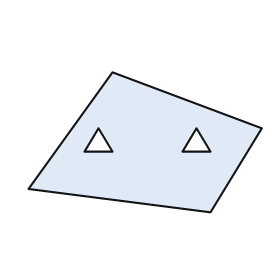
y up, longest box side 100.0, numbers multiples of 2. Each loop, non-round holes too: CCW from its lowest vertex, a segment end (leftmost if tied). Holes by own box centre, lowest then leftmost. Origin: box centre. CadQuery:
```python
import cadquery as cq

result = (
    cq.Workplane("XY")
    .moveTo(28.0, -30.0)
    .lineTo(50.0, 6.0)
    .lineTo(-14.0, 30.0)
    .lineTo(-50.0, -20.0)
    .close()
    .moveTo(-26.0, -4.0)
    .lineTo(-14.0, -4.0)
    .lineTo(-20.0, 6.0)
    .close()
    .moveTo(16.0, -4.0)
    .lineTo(28.0, -4.0)
    .lineTo(22.0, 6.0)
    .close()
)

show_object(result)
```